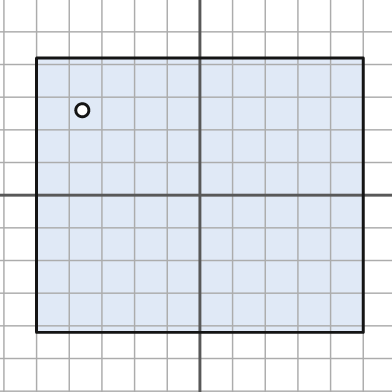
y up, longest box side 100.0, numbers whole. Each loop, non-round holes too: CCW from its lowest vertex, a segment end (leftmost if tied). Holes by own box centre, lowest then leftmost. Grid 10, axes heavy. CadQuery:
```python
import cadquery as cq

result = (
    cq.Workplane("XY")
    .moveTo(-50.0, -42.0)
    .lineTo(50.0, -42.0)
    .lineTo(50.0, 42.0)
    .lineTo(-50.0, 42.0)
    .close()
    .moveTo(-36.0, 26.0)
    .circle(2.0)
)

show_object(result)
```